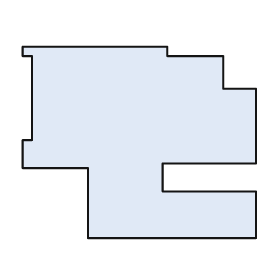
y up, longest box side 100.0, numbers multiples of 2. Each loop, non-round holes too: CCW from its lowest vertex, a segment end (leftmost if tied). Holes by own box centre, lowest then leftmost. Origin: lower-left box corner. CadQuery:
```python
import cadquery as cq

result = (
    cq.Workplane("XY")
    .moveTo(28.0, 0.0)
    .lineTo(100.0, 0.0)
    .lineTo(100.0, 20.0)
    .lineTo(60.0, 20.0)
    .lineTo(60.0, 32.0)
    .lineTo(100.0, 32.0)
    .lineTo(100.0, 64.0)
    .lineTo(86.0, 64.0)
    .lineTo(86.0, 78.0)
    .lineTo(62.0, 78.0)
    .lineTo(62.0, 82.0)
    .lineTo(0.0, 82.0)
    .lineTo(0.0, 78.0)
    .lineTo(4.0, 78.0)
    .lineTo(4.0, 42.0)
    .lineTo(0.0, 42.0)
    .lineTo(0.0, 30.0)
    .lineTo(28.0, 30.0)
    .close()
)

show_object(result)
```